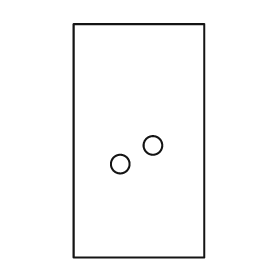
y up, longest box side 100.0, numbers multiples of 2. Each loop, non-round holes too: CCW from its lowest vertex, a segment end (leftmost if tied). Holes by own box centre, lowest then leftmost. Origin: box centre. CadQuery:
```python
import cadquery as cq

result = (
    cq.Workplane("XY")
    .moveTo(-28.0, -50.0)
    .lineTo(28.0, -50.0)
    .lineTo(28.0, 50.0)
    .lineTo(-28.0, 50.0)
    .close()
    .moveTo(-8.0, -10.0)
    .circle(4.0)
    .moveTo(6.0, -2.0)
    .circle(4.0)
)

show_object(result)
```